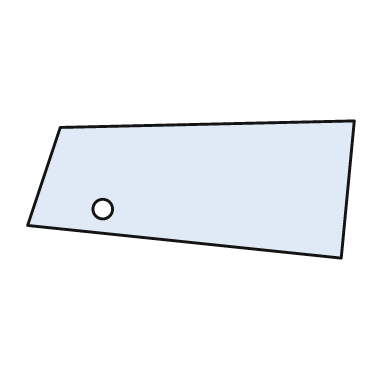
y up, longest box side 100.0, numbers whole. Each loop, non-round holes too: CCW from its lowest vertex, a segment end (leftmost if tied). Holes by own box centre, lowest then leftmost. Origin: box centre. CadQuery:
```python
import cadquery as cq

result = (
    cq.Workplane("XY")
    .moveTo(46.0, -21.0)
    .lineTo(50.0, 21.0)
    .lineTo(-40.0, 19.0)
    .lineTo(-50.0, -11.0)
    .close()
    .moveTo(-27.0, -6.0)
    .circle(3.0)
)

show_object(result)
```